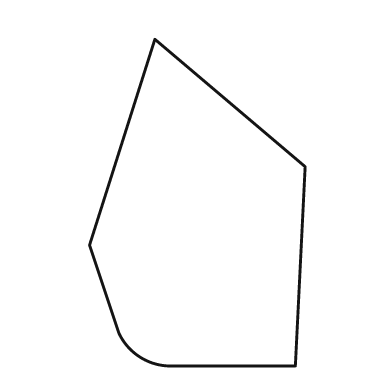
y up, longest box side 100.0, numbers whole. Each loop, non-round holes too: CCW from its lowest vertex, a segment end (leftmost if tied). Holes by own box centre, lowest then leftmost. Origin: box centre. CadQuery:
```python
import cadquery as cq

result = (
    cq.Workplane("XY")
    .moveTo(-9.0, -50.0)
    .lineTo(30.0, -50.0)
    .lineTo(33.0, 11.0)
    .lineTo(-13.0, 50.0)
    .lineTo(-33.0, -13.0)
    .lineTo(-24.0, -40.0)
    .threePointArc((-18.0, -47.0), (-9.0, -50.0))
    .close()
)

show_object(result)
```